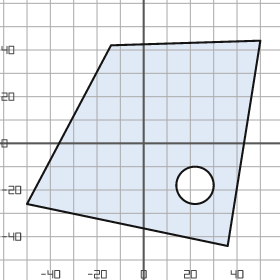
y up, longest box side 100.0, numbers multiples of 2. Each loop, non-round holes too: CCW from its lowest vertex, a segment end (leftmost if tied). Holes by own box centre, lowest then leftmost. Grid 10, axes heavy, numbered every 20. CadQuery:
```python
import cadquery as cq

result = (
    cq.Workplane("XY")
    .moveTo(36.0, -44.0)
    .lineTo(50.0, 44.0)
    .lineTo(-14.0, 42.0)
    .lineTo(-50.0, -26.0)
    .close()
    .moveTo(22.0, -18.0)
    .circle(8.0)
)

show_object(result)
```